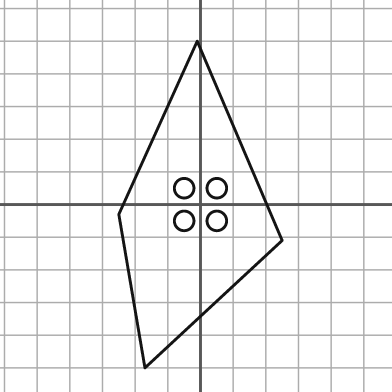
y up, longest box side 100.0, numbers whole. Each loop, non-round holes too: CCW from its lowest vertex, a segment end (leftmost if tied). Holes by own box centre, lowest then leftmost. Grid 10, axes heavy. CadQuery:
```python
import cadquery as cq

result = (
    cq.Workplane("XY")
    .moveTo(-17.0, -50.0)
    .lineTo(25.0, -11.0)
    .lineTo(-1.0, 50.0)
    .lineTo(-25.0, -3.0)
    .close()
    .moveTo(-5.0, -5.0)
    .circle(3.0)
    .moveTo(5.0, -5.0)
    .circle(3.0)
    .moveTo(-5.0, 5.0)
    .circle(3.0)
    .moveTo(5.0, 5.0)
    .circle(3.0)
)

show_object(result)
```